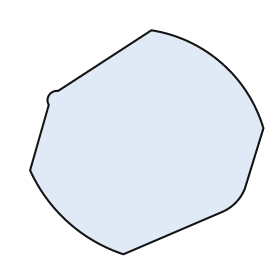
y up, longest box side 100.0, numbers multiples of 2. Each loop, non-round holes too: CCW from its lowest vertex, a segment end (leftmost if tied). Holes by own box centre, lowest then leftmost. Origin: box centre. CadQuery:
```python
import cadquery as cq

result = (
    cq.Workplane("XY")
    .moveTo(-10.0, -48.0)
    .lineTo(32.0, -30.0)
    .threePointArc((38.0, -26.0), (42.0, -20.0))
    .lineTo(50.0, 6.0)
    .threePointArc((32.0, 34.0), (2.0, 48.0))
    .lineTo(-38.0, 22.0)
    .threePointArc((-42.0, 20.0), (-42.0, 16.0))
    .lineTo(-50.0, -12.0)
    .threePointArc((-34.0, -34.0), (-10.0, -48.0))
    .close()
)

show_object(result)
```